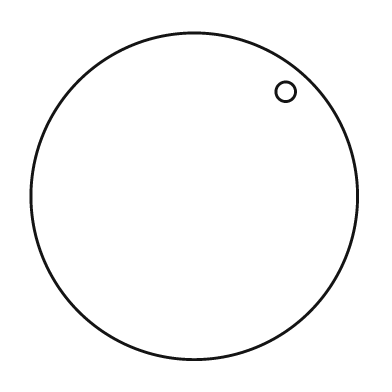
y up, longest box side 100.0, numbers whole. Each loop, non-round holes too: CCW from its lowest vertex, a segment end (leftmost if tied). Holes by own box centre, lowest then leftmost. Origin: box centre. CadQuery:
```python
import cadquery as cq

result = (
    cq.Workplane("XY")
    .moveTo(0.0, 0.0)
    .circle(50.0)
    .moveTo(28.0, 32.0)
    .circle(3.0)
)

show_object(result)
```